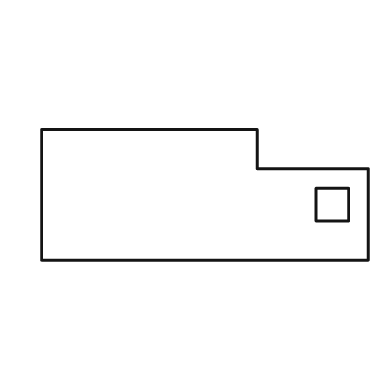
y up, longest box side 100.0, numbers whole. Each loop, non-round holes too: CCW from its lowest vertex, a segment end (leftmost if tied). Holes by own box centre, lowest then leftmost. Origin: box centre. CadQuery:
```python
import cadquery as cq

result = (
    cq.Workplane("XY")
    .moveTo(-50.0, -20.0)
    .lineTo(50.0, -20.0)
    .lineTo(50.0, 8.0)
    .lineTo(16.0, 8.0)
    .lineTo(16.0, 20.0)
    .lineTo(-50.0, 20.0)
    .close()
    .moveTo(34.0, -8.0)
    .lineTo(44.0, -8.0)
    .lineTo(44.0, 2.0)
    .lineTo(34.0, 2.0)
    .close()
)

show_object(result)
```